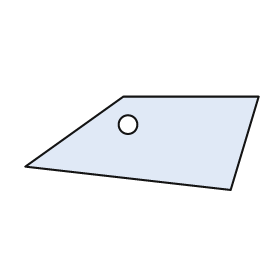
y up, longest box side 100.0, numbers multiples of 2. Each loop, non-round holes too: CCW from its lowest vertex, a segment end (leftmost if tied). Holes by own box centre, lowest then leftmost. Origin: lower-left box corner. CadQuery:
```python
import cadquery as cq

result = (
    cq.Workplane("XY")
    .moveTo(88.0, 0.0)
    .lineTo(100.0, 40.0)
    .lineTo(42.0, 40.0)
    .lineTo(0.0, 10.0)
    .close()
    .moveTo(44.0, 28.0)
    .circle(4.0)
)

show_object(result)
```